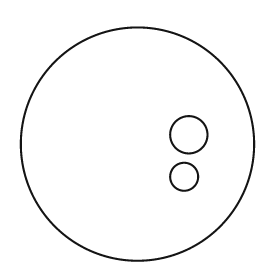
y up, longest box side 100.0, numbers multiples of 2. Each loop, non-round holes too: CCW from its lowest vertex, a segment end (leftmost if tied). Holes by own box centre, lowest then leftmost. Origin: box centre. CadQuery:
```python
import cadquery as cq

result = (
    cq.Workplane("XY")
    .moveTo(0.0, 0.0)
    .circle(50.0)
    .moveTo(20.0, -14.0)
    .circle(6.0)
    .moveTo(22.0, 4.0)
    .circle(8.0)
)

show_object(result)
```